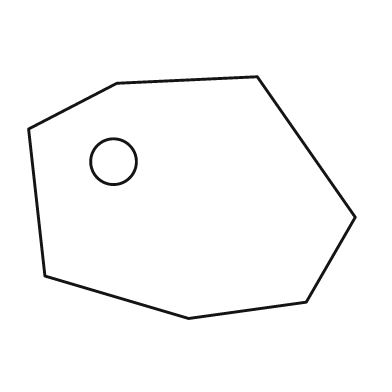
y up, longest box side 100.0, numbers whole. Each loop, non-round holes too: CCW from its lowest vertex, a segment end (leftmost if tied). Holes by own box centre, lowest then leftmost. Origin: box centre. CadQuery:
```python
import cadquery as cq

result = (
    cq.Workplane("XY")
    .moveTo(-1.0, -37.0)
    .lineTo(35.0, -32.0)
    .lineTo(50.0, -6.0)
    .lineTo(20.0, 37.0)
    .lineTo(-23.0, 35.0)
    .lineTo(-50.0, 21.0)
    .lineTo(-45.0, -24.0)
    .close()
    .moveTo(-24.0, 11.0)
    .circle(7.0)
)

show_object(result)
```